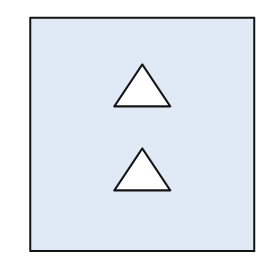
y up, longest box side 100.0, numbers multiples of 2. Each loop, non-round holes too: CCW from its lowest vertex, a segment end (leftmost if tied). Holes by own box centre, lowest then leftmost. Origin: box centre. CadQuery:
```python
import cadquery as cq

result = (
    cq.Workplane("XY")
    .moveTo(-48.0, -50.0)
    .lineTo(48.0, -50.0)
    .lineTo(48.0, 50.0)
    .lineTo(-48.0, 50.0)
    .close()
    .moveTo(-12.0, -24.0)
    .lineTo(12.0, -24.0)
    .lineTo(0.0, -6.0)
    .close()
    .moveTo(-12.0, 12.0)
    .lineTo(12.0, 12.0)
    .lineTo(0.0, 30.0)
    .close()
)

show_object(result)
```